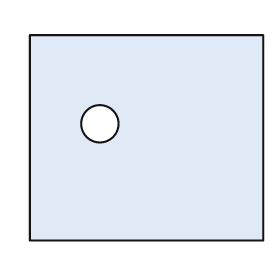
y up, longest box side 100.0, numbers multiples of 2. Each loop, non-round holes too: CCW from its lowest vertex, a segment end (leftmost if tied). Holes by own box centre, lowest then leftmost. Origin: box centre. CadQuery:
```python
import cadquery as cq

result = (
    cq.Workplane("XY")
    .moveTo(-50.0, -44.0)
    .lineTo(50.0, -44.0)
    .lineTo(50.0, 44.0)
    .lineTo(-50.0, 44.0)
    .close()
    .moveTo(-20.0, 6.0)
    .circle(8.0)
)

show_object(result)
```